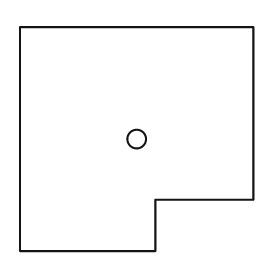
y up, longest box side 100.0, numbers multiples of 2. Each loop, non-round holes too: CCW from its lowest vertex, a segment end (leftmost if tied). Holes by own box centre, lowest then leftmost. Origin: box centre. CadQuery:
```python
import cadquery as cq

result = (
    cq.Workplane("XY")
    .moveTo(-50.0, -48.0)
    .lineTo(8.0, -48.0)
    .lineTo(8.0, -26.0)
    .lineTo(50.0, -26.0)
    .lineTo(50.0, 48.0)
    .lineTo(-50.0, 48.0)
    .close()
    .moveTo(0.0, 0.0)
    .circle(4.0)
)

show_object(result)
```